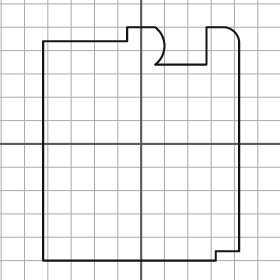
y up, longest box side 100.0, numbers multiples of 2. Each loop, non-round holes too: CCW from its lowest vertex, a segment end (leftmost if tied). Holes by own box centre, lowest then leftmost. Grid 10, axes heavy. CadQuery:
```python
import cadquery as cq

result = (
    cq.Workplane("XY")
    .moveTo(-42.0, -50.0)
    .lineTo(32.0, -50.0)
    .lineTo(32.0, -46.0)
    .lineTo(42.0, -46.0)
    .lineTo(42.0, 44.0)
    .threePointArc((40.0, 48.0), (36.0, 50.0))
    .lineTo(28.0, 50.0)
    .lineTo(28.0, 34.0)
    .lineTo(6.0, 34.0)
    .threePointArc((10.0, 42.0), (6.0, 50.0))
    .lineTo(-6.0, 50.0)
    .lineTo(-6.0, 44.0)
    .lineTo(-42.0, 44.0)
    .close()
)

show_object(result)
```